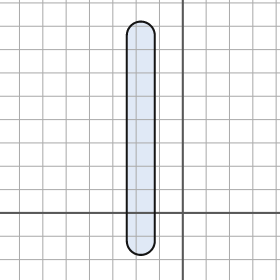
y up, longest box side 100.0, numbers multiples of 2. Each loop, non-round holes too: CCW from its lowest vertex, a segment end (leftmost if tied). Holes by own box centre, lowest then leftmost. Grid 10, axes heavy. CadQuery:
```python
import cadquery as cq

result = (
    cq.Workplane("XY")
    .moveTo(-24.0, -12.0)
    .threePointArc((-18.0, -18.0), (-12.0, -12.0))
    .lineTo(-12.0, 76.0)
    .threePointArc((-18.0, 82.0), (-24.0, 76.0))
    .close()
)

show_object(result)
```